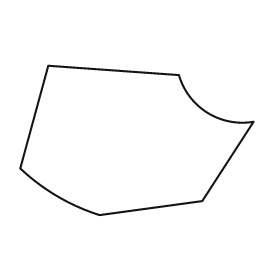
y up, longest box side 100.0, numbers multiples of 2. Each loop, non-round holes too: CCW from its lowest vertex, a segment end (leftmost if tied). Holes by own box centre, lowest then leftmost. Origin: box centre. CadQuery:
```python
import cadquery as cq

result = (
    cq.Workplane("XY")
    .moveTo(-16.0, -32.0)
    .lineTo(28.0, -26.0)
    .lineTo(50.0, 8.0)
    .threePointArc((30.0, 12.0), (18.0, 28.0))
    .lineTo(-38.0, 32.0)
    .lineTo(-50.0, -12.0)
    .threePointArc((-34.0, -24.0), (-16.0, -32.0))
    .close()
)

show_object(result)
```